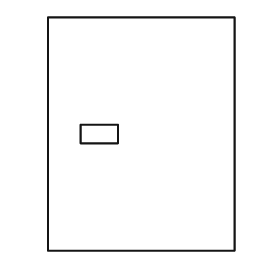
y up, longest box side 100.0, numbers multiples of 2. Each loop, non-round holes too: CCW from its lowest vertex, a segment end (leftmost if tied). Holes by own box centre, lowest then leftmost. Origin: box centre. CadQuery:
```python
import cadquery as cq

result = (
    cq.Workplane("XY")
    .moveTo(-40.0, -50.0)
    .lineTo(40.0, -50.0)
    .lineTo(40.0, 50.0)
    .lineTo(-40.0, 50.0)
    .close()
    .moveTo(-26.0, -4.0)
    .lineTo(-10.0, -4.0)
    .lineTo(-10.0, 4.0)
    .lineTo(-26.0, 4.0)
    .close()
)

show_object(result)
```